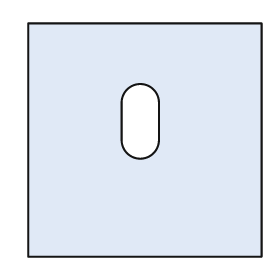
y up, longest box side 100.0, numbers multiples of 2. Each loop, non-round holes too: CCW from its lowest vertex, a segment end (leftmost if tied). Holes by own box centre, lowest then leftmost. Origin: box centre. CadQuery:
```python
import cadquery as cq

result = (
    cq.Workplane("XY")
    .moveTo(-50.0, -50.0)
    .lineTo(50.0, -50.0)
    .lineTo(50.0, 50.0)
    .lineTo(-50.0, 50.0)
    .close()
    .moveTo(-10.0, 0.0)
    .threePointArc((-2.0, -8.0), (6.0, 0.0))
    .lineTo(6.0, 16.0)
    .threePointArc((-2.0, 24.0), (-10.0, 16.0))
    .close()
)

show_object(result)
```